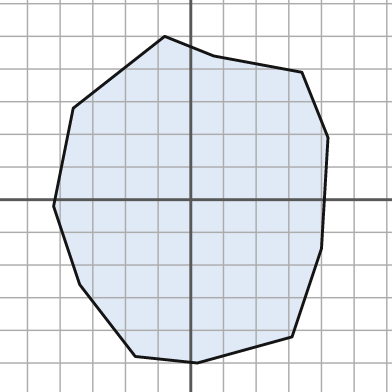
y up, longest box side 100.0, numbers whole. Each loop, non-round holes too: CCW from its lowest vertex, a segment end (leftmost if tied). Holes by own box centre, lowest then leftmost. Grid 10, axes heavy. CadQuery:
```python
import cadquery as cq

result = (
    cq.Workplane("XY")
    .moveTo(2.0, -50.0)
    .lineTo(31.0, -42.0)
    .lineTo(40.0, -15.0)
    .lineTo(42.0, 19.0)
    .lineTo(34.0, 39.0)
    .lineTo(7.0, 44.0)
    .lineTo(-8.0, 50.0)
    .lineTo(-36.0, 28.0)
    .lineTo(-42.0, -2.0)
    .lineTo(-34.0, -26.0)
    .lineTo(-17.0, -48.0)
    .close()
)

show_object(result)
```